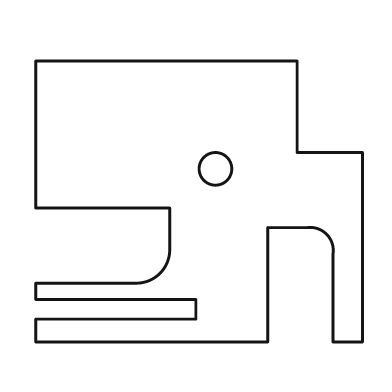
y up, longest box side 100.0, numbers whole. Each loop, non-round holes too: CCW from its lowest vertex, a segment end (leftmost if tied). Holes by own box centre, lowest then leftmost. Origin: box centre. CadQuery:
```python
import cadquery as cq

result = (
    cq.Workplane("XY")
    .moveTo(-50.0, -43.0)
    .lineTo(21.0, -43.0)
    .lineTo(21.0, -8.0)
    .lineTo(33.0, -8.0)
    .threePointArc((39.0, -10.0), (41.0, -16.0))
    .lineTo(41.0, -43.0)
    .lineTo(50.0, -43.0)
    .lineTo(50.0, 15.0)
    .lineTo(30.0, 15.0)
    .lineTo(30.0, 43.0)
    .lineTo(-50.0, 43.0)
    .lineTo(-50.0, -2.0)
    .lineTo(-9.0, -2.0)
    .lineTo(-9.0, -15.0)
    .threePointArc((-12.0, -22.0), (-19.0, -25.0))
    .lineTo(-50.0, -25.0)
    .lineTo(-50.0, -30.0)
    .lineTo(-1.0, -30.0)
    .lineTo(-1.0, -36.0)
    .lineTo(-50.0, -36.0)
    .close()
    .moveTo(5.0, 10.0)
    .circle(5.0)
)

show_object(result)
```